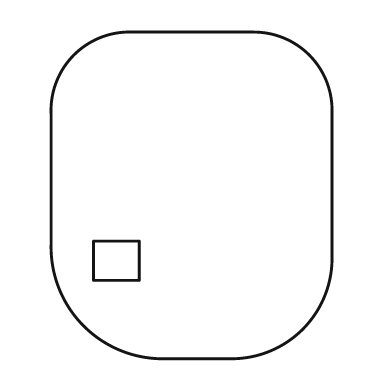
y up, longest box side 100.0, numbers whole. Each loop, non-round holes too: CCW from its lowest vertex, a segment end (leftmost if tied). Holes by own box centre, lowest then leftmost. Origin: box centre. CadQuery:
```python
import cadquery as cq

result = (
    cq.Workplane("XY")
    .moveTo(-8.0, -50.0)
    .lineTo(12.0, -50.0)
    .threePointArc((34.0, -41.0), (43.0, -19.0))
    .lineTo(43.0, 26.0)
    .threePointArc((36.0, 43.0), (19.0, 50.0))
    .lineTo(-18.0, 50.0)
    .threePointArc((-36.0, 43.0), (-43.0, 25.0))
    .lineTo(-43.0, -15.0)
    .threePointArc((-33.0, -40.0), (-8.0, -50.0))
    .close()
    .moveTo(-30.0, -26.0)
    .lineTo(-16.0, -26.0)
    .lineTo(-16.0, -14.0)
    .lineTo(-30.0, -14.0)
    .close()
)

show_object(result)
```